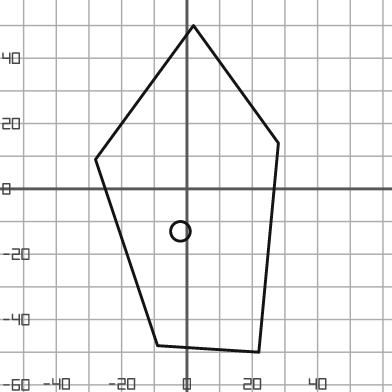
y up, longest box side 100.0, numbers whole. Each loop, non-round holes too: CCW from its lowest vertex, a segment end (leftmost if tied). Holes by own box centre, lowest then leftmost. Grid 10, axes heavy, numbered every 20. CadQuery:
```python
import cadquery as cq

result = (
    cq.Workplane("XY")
    .moveTo(22.0, -50.0)
    .lineTo(28.0, 14.0)
    .lineTo(2.0, 50.0)
    .lineTo(-28.0, 9.0)
    .lineTo(-9.0, -48.0)
    .close()
    .moveTo(-2.0, -13.0)
    .circle(3.0)
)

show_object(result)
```